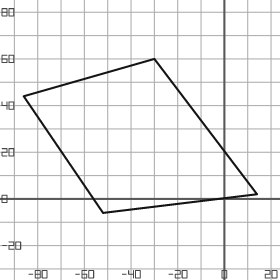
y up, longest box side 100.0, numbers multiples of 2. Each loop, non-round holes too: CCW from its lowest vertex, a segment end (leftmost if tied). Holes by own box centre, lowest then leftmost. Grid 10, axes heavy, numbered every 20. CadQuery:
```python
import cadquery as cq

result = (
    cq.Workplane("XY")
    .moveTo(-52.0, -6.0)
    .lineTo(14.0, 2.0)
    .lineTo(-30.0, 60.0)
    .lineTo(-86.0, 44.0)
    .close()
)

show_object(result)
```